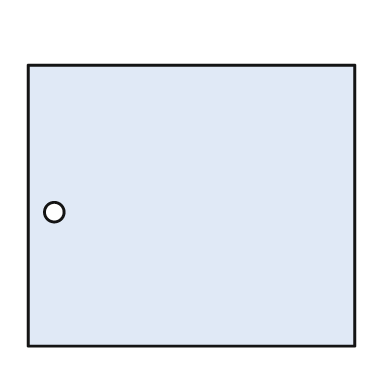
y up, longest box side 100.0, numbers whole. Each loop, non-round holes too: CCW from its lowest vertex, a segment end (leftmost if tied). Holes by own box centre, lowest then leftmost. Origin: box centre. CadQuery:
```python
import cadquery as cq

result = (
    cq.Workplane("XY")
    .moveTo(-50.0, -43.0)
    .lineTo(50.0, -43.0)
    .lineTo(50.0, 43.0)
    .lineTo(-50.0, 43.0)
    .close()
    .moveTo(-42.0, -2.0)
    .circle(3.0)
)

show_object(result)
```